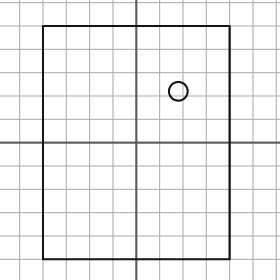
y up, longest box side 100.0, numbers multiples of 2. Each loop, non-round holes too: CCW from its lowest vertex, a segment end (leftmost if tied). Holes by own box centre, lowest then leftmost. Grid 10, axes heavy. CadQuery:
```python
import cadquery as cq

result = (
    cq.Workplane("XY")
    .moveTo(-40.0, -50.0)
    .lineTo(40.0, -50.0)
    .lineTo(40.0, 50.0)
    .lineTo(-40.0, 50.0)
    .close()
    .moveTo(18.0, 22.0)
    .circle(4.0)
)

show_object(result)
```